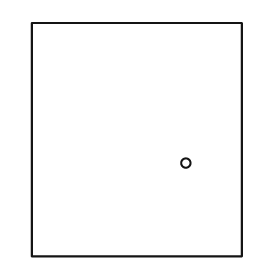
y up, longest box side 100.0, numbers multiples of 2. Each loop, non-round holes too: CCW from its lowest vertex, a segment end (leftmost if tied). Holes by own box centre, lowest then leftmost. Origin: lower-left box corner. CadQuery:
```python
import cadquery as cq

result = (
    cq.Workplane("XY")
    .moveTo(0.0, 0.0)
    .lineTo(90.0, 0.0)
    .lineTo(90.0, 100.0)
    .lineTo(0.0, 100.0)
    .close()
    .moveTo(66.0, 40.0)
    .circle(2.0)
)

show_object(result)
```